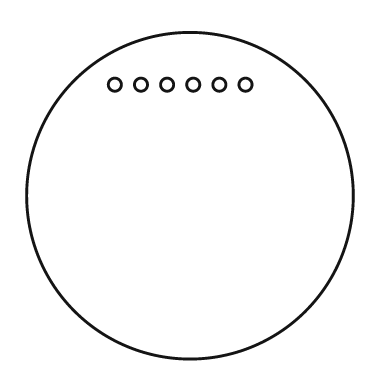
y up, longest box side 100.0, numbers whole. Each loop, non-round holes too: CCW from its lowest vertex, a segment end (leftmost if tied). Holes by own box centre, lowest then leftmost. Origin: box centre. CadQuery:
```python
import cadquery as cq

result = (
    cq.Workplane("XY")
    .moveTo(0.0, 0.0)
    .circle(50.0)
    .moveTo(-23.0, 34.0)
    .circle(2.0)
    .moveTo(-15.0, 34.0)
    .circle(2.0)
    .moveTo(-7.0, 34.0)
    .circle(2.0)
    .moveTo(1.0, 34.0)
    .circle(2.0)
    .moveTo(9.0, 34.0)
    .circle(2.0)
    .moveTo(17.0, 34.0)
    .circle(2.0)
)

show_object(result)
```